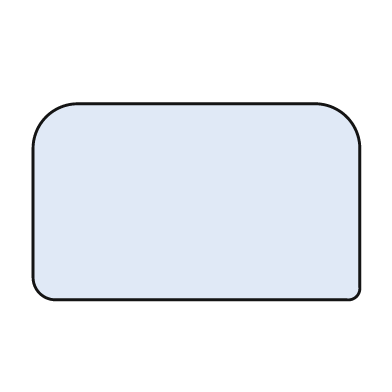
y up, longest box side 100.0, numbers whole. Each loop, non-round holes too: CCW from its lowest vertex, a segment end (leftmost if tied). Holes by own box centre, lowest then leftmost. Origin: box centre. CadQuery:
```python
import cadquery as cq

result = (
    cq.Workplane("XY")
    .moveTo(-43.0, -30.0)
    .lineTo(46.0, -30.0)
    .threePointArc((49.0, -29.0), (50.0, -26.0))
    .lineTo(50.0, 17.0)
    .threePointArc((46.0, 26.0), (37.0, 30.0))
    .lineTo(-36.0, 30.0)
    .threePointArc((-46.0, 26.0), (-50.0, 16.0))
    .lineTo(-50.0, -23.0)
    .threePointArc((-48.0, -28.0), (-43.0, -30.0))
    .close()
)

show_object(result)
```